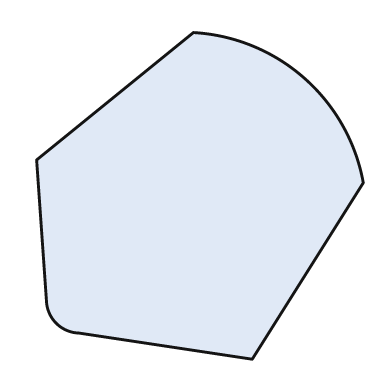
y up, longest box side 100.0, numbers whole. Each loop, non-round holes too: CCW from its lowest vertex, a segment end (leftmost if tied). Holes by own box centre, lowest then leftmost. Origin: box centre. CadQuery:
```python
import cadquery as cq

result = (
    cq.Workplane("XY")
    .moveTo(16.0, -50.0)
    .lineTo(50.0, 4.0)
    .threePointArc((32.0, 36.0), (-2.0, 50.0))
    .lineTo(-50.0, 11.0)
    .lineTo(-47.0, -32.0)
    .threePointArc((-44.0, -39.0), (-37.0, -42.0))
    .close()
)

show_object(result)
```